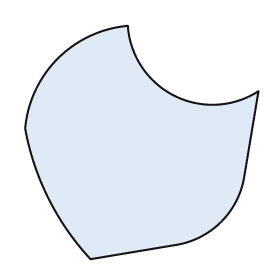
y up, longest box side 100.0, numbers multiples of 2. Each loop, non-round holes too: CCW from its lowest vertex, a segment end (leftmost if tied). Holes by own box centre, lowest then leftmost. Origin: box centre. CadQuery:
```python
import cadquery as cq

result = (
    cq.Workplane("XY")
    .moveTo(-22.0, -50.0)
    .lineTo(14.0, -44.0)
    .threePointArc((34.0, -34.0), (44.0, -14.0))
    .lineTo(50.0, 22.0)
    .threePointArc((14.0, 20.0), (-6.0, 50.0))
    .threePointArc((-36.0, 36.0), (-50.0, 6.0))
    .threePointArc((-40.0, -24.0), (-22.0, -50.0))
    .close()
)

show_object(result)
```